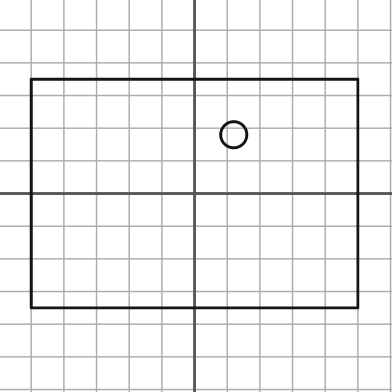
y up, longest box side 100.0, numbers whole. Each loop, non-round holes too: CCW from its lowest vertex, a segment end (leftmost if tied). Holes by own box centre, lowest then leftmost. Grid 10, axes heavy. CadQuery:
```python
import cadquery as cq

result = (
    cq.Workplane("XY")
    .moveTo(-50.0, -35.0)
    .lineTo(50.0, -35.0)
    .lineTo(50.0, 35.0)
    .lineTo(-50.0, 35.0)
    .close()
    .moveTo(12.0, 18.0)
    .circle(4.0)
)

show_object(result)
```